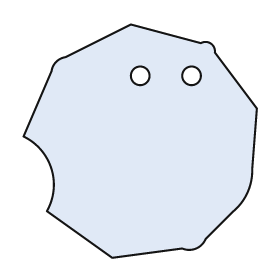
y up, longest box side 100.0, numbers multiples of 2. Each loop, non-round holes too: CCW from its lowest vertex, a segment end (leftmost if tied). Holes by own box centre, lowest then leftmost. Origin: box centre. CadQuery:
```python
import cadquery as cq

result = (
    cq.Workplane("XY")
    .moveTo(-12.0, -50.0)
    .lineTo(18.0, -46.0)
    .threePointArc((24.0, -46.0), (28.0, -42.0))
    .lineTo(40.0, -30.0)
    .threePointArc((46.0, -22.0), (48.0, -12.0))
    .lineTo(50.0, 14.0)
    .lineTo(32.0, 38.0)
    .threePointArc((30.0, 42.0), (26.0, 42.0))
    .lineTo(-4.0, 50.0)
    .lineTo(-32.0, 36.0)
    .threePointArc((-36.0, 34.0), (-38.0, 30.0))
    .lineTo(-50.0, 2.0)
    .threePointArc((-38.0, -12.0), (-40.0, -30.0))
    .close()
    .moveTo(0.0, 28.0)
    .circle(4.0)
    .moveTo(22.0, 28.0)
    .circle(4.0)
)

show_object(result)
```